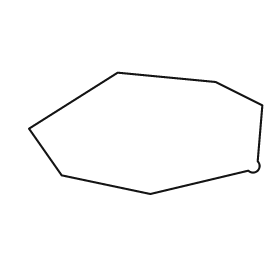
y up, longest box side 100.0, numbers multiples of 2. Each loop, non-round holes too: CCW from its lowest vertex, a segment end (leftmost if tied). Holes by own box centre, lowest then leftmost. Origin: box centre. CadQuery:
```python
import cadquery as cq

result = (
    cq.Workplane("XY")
    .moveTo(2.0, -26.0)
    .lineTo(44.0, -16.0)
    .threePointArc((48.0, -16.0), (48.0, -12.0))
    .lineTo(50.0, 12.0)
    .lineTo(30.0, 22.0)
    .lineTo(-12.0, 26.0)
    .lineTo(-50.0, 2.0)
    .lineTo(-36.0, -18.0)
    .close()
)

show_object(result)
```